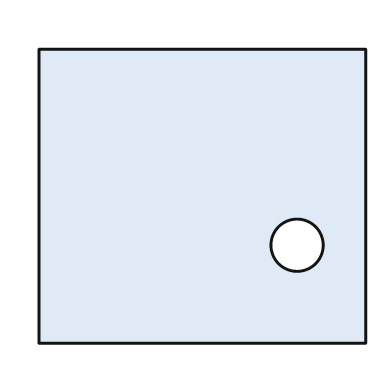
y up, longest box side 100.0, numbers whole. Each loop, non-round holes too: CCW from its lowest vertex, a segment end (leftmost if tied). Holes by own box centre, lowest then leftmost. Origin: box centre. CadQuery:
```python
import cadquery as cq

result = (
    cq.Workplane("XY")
    .moveTo(-50.0, -45.0)
    .lineTo(50.0, -45.0)
    .lineTo(50.0, 45.0)
    .lineTo(-50.0, 45.0)
    .close()
    .moveTo(29.0, -15.0)
    .circle(8.0)
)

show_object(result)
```